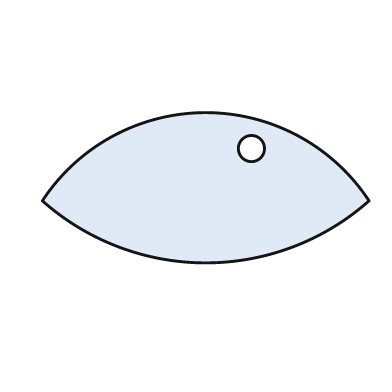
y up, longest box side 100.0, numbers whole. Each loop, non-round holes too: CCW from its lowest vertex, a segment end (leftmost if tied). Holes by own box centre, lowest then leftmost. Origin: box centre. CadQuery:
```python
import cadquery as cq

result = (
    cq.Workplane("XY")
    .moveTo(-50.0, -4.0)
    .threePointArc((0.0, -23.0), (50.0, -4.0))
    .threePointArc((0.0, 23.0), (-50.0, -4.0))
    .close()
    .moveTo(14.0, 12.0)
    .circle(4.0)
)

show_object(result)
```